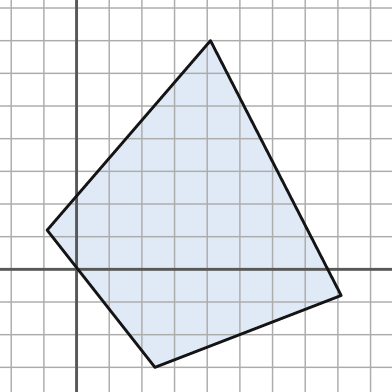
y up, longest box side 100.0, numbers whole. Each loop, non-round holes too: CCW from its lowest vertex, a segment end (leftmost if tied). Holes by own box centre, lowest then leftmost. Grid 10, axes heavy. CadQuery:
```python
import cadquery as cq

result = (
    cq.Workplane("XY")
    .moveTo(24.0, -30.0)
    .lineTo(81.0, -8.0)
    .lineTo(41.0, 70.0)
    .lineTo(-9.0, 12.0)
    .close()
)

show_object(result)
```